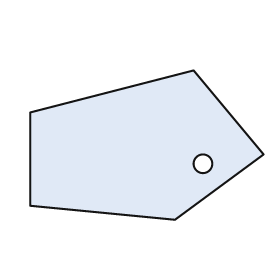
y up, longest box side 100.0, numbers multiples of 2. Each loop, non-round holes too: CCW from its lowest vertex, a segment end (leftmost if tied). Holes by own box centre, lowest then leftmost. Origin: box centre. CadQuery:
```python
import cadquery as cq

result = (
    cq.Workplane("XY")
    .moveTo(12.0, -32.0)
    .lineTo(50.0, -4.0)
    .lineTo(20.0, 32.0)
    .lineTo(-50.0, 14.0)
    .lineTo(-50.0, -26.0)
    .close()
    .moveTo(24.0, -8.0)
    .circle(4.0)
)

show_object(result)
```